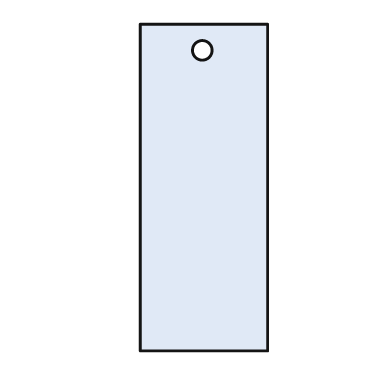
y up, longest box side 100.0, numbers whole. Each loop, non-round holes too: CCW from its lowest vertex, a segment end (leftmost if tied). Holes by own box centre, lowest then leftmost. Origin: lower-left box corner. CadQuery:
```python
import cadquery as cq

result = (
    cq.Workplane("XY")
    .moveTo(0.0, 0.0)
    .lineTo(39.0, 0.0)
    .lineTo(39.0, 100.0)
    .lineTo(0.0, 100.0)
    .close()
    .moveTo(19.0, 92.0)
    .circle(3.0)
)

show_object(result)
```